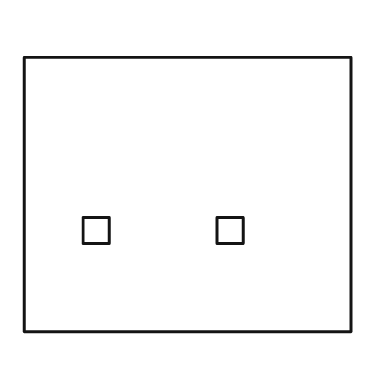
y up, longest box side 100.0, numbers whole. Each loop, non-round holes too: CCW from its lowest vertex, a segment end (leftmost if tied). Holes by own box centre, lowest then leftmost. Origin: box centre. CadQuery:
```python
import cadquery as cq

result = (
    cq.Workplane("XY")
    .moveTo(-50.0, -42.0)
    .lineTo(50.0, -42.0)
    .lineTo(50.0, 42.0)
    .lineTo(-50.0, 42.0)
    .close()
    .moveTo(-32.0, -15.0)
    .lineTo(-24.0, -15.0)
    .lineTo(-24.0, -7.0)
    .lineTo(-32.0, -7.0)
    .close()
    .moveTo(9.0, -15.0)
    .lineTo(17.0, -15.0)
    .lineTo(17.0, -7.0)
    .lineTo(9.0, -7.0)
    .close()
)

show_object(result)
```